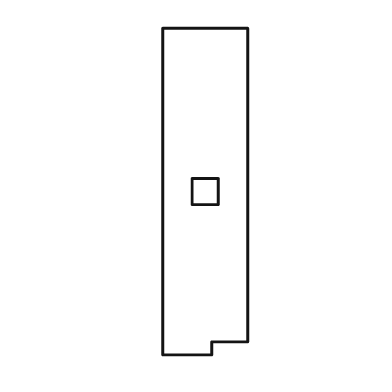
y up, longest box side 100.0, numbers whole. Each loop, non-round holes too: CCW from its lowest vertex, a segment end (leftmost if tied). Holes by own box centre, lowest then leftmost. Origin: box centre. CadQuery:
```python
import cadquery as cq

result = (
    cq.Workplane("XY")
    .moveTo(-13.0, -50.0)
    .lineTo(2.0, -50.0)
    .lineTo(2.0, -46.0)
    .lineTo(13.0, -46.0)
    .lineTo(13.0, 50.0)
    .lineTo(-13.0, 50.0)
    .close()
    .moveTo(-4.0, -4.0)
    .lineTo(4.0, -4.0)
    .lineTo(4.0, 4.0)
    .lineTo(-4.0, 4.0)
    .close()
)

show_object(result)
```